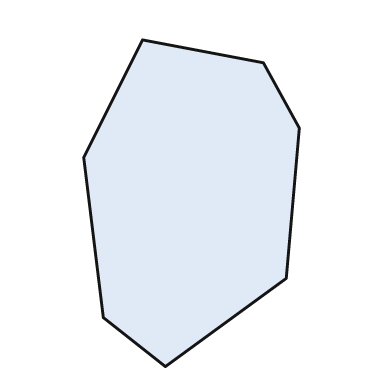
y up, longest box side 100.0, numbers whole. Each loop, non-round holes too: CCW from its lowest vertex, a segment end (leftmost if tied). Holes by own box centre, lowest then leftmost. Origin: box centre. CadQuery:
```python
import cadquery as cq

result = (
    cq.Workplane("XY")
    .moveTo(-8.0, -50.0)
    .lineTo(29.0, -23.0)
    .lineTo(33.0, 23.0)
    .lineTo(22.0, 43.0)
    .lineTo(-15.0, 50.0)
    .lineTo(-33.0, 14.0)
    .lineTo(-27.0, -35.0)
    .close()
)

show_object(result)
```